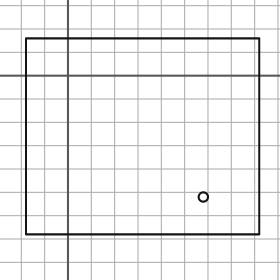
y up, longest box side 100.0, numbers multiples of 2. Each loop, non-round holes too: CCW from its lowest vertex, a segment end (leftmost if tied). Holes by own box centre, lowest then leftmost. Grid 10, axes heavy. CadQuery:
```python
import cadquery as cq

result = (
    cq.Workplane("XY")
    .moveTo(-18.0, -68.0)
    .lineTo(82.0, -68.0)
    .lineTo(82.0, 16.0)
    .lineTo(-18.0, 16.0)
    .close()
    .moveTo(58.0, -52.0)
    .circle(2.0)
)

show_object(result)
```